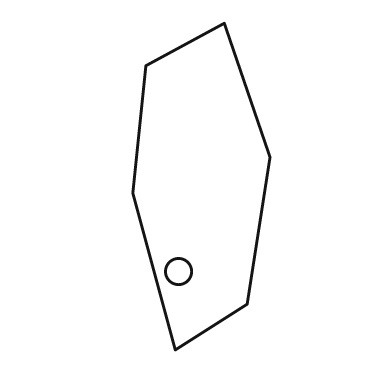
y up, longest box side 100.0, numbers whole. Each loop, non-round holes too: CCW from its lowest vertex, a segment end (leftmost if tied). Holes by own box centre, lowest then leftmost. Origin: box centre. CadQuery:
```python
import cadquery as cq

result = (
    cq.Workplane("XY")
    .moveTo(-8.0, -50.0)
    .lineTo(14.0, -36.0)
    .lineTo(21.0, 9.0)
    .lineTo(7.0, 50.0)
    .lineTo(-17.0, 37.0)
    .lineTo(-21.0, -2.0)
    .close()
    .moveTo(-7.0, -26.0)
    .circle(4.0)
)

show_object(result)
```